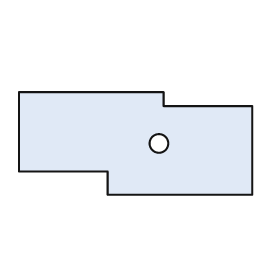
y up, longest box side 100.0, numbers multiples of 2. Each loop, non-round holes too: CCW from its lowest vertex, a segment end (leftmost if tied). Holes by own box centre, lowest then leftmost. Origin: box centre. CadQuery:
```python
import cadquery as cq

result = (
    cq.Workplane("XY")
    .moveTo(-12.0, -22.0)
    .lineTo(50.0, -22.0)
    .lineTo(50.0, 16.0)
    .lineTo(12.0, 16.0)
    .lineTo(12.0, 22.0)
    .lineTo(-50.0, 22.0)
    .lineTo(-50.0, -12.0)
    .lineTo(-12.0, -12.0)
    .close()
    .moveTo(10.0, 0.0)
    .circle(4.0)
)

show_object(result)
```